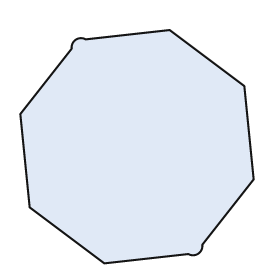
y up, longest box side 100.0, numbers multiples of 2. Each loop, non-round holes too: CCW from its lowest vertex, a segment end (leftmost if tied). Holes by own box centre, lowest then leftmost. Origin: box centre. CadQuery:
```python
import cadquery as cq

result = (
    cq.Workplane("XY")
    .moveTo(-14.0, -50.0)
    .lineTo(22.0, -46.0)
    .threePointArc((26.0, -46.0), (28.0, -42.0))
    .lineTo(50.0, -14.0)
    .lineTo(46.0, 26.0)
    .lineTo(14.0, 50.0)
    .lineTo(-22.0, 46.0)
    .threePointArc((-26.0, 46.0), (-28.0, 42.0))
    .lineTo(-50.0, 14.0)
    .lineTo(-46.0, -26.0)
    .close()
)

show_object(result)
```